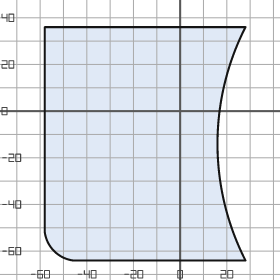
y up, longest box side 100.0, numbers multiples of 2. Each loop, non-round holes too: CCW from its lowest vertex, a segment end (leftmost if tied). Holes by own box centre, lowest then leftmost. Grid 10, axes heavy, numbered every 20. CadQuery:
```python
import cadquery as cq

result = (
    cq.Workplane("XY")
    .moveTo(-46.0, -64.0)
    .lineTo(28.0, -64.0)
    .threePointArc((16.0, -14.0), (28.0, 36.0))
    .lineTo(-58.0, 36.0)
    .lineTo(-58.0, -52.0)
    .threePointArc((-54.0, -60.0), (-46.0, -64.0))
    .close()
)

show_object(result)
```